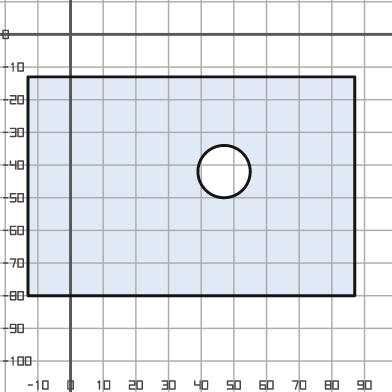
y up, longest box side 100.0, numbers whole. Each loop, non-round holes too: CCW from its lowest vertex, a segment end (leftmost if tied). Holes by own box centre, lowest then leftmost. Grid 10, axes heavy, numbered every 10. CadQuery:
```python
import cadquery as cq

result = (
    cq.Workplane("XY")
    .moveTo(-13.0, -80.0)
    .lineTo(87.0, -80.0)
    .lineTo(87.0, -13.0)
    .lineTo(-13.0, -13.0)
    .close()
    .moveTo(47.0, -42.0)
    .circle(8.0)
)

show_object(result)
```